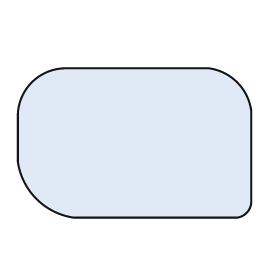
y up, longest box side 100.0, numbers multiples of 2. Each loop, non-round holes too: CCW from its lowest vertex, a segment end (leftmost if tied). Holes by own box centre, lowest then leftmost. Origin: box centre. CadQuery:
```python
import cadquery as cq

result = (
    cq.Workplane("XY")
    .moveTo(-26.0, -32.0)
    .lineTo(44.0, -32.0)
    .threePointArc((48.0, -30.0), (50.0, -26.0))
    .lineTo(50.0, 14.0)
    .threePointArc((44.0, 26.0), (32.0, 32.0))
    .lineTo(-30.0, 32.0)
    .threePointArc((-44.0, 26.0), (-50.0, 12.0))
    .lineTo(-50.0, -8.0)
    .threePointArc((-42.0, -24.0), (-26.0, -32.0))
    .close()
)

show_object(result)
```